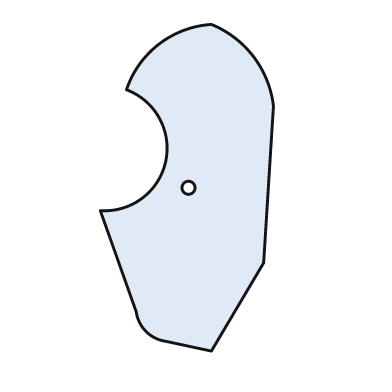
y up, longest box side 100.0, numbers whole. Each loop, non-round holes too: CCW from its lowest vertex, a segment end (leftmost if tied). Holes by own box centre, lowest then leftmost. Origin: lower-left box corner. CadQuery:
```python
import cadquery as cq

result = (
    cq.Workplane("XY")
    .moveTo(34.0, 0.0)
    .lineTo(50.0, 27.0)
    .lineTo(53.0, 75.0)
    .threePointArc((47.0, 90.0), (34.0, 100.0))
    .threePointArc((18.0, 94.0), (8.0, 80.0))
    .threePointArc((20.0, 58.0), (0.0, 43.0))
    .lineTo(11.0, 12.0)
    .threePointArc((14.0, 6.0), (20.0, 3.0))
    .close()
    .moveTo(27.0, 50.0)
    .circle(2.0)
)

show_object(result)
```